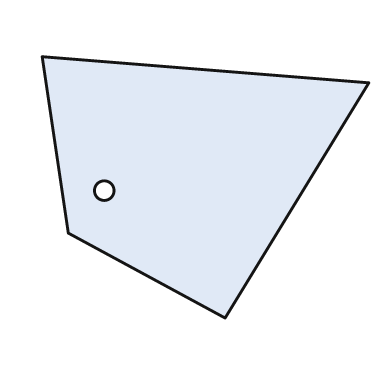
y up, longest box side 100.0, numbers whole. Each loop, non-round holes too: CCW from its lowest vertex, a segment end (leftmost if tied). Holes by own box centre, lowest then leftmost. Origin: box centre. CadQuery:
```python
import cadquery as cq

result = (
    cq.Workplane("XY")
    .moveTo(6.0, -40.0)
    .lineTo(50.0, 32.0)
    .lineTo(-50.0, 40.0)
    .lineTo(-42.0, -14.0)
    .close()
    .moveTo(-31.0, -1.0)
    .circle(3.0)
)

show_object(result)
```